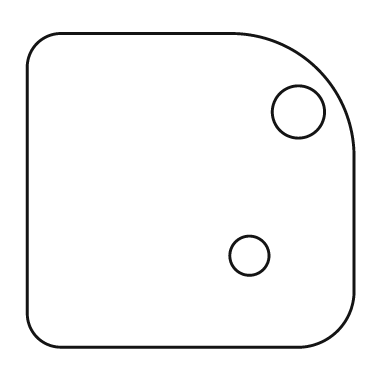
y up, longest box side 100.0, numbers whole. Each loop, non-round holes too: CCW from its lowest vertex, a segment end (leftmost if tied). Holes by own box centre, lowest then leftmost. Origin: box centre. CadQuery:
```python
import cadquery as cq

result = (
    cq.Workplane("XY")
    .moveTo(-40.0, -48.0)
    .lineTo(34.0, -48.0)
    .threePointArc((45.0, -43.0), (50.0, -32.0))
    .lineTo(50.0, 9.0)
    .threePointArc((39.0, 37.0), (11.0, 48.0))
    .lineTo(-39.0, 48.0)
    .threePointArc((-47.0, 45.0), (-50.0, 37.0))
    .lineTo(-50.0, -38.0)
    .threePointArc((-47.0, -45.0), (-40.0, -48.0))
    .close()
    .moveTo(18.0, -20.0)
    .circle(6.0)
    .moveTo(33.0, 24.0)
    .circle(8.0)
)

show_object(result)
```